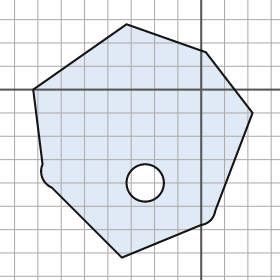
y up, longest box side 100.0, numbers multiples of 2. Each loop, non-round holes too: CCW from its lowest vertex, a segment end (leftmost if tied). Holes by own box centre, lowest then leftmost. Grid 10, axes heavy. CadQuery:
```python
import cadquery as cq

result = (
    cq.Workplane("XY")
    .moveTo(-34.0, -72.0)
    .lineTo(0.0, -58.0)
    .threePointArc((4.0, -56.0), (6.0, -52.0))
    .lineTo(22.0, -10.0)
    .lineTo(2.0, 16.0)
    .lineTo(-32.0, 28.0)
    .lineTo(-72.0, 0.0)
    .lineTo(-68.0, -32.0)
    .threePointArc((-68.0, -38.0), (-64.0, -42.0))
    .close()
    .moveTo(-24.0, -40.0)
    .circle(8.0)
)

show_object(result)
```